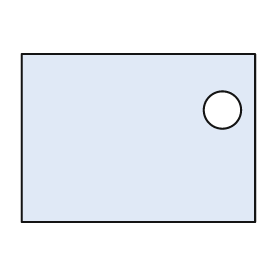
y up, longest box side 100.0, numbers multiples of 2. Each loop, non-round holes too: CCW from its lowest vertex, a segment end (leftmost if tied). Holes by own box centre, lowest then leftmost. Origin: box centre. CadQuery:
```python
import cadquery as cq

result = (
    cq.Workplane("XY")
    .moveTo(-50.0, -36.0)
    .lineTo(50.0, -36.0)
    .lineTo(50.0, 36.0)
    .lineTo(-50.0, 36.0)
    .close()
    .moveTo(36.0, 12.0)
    .circle(8.0)
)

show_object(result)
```